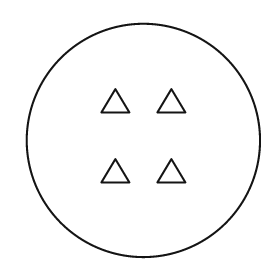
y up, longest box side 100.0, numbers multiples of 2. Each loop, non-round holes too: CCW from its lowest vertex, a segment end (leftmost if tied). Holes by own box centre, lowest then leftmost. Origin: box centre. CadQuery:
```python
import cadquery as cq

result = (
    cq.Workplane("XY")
    .moveTo(0.0, 0.0)
    .circle(50.0)
    .moveTo(-18.0, -18.0)
    .lineTo(-6.0, -18.0)
    .lineTo(-12.0, -8.0)
    .close()
    .moveTo(6.0, -18.0)
    .lineTo(18.0, -18.0)
    .lineTo(12.0, -8.0)
    .close()
    .moveTo(-18.0, 12.0)
    .lineTo(-6.0, 12.0)
    .lineTo(-12.0, 22.0)
    .close()
    .moveTo(6.0, 12.0)
    .lineTo(18.0, 12.0)
    .lineTo(12.0, 22.0)
    .close()
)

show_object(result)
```